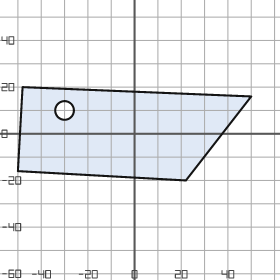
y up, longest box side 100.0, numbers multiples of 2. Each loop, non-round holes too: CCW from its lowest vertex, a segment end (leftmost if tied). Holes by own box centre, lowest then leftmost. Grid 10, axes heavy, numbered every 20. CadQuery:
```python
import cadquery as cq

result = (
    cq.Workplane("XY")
    .moveTo(22.0, -20.0)
    .lineTo(50.0, 16.0)
    .lineTo(-48.0, 20.0)
    .lineTo(-50.0, -16.0)
    .close()
    .moveTo(-30.0, 10.0)
    .circle(4.0)
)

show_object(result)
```